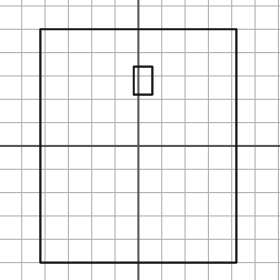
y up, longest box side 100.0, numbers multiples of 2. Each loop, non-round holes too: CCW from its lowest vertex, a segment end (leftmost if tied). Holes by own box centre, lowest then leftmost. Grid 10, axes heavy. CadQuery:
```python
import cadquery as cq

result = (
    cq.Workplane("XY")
    .moveTo(-42.0, -50.0)
    .lineTo(42.0, -50.0)
    .lineTo(42.0, 50.0)
    .lineTo(-42.0, 50.0)
    .close()
    .moveTo(-2.0, 22.0)
    .lineTo(6.0, 22.0)
    .lineTo(6.0, 34.0)
    .lineTo(-2.0, 34.0)
    .close()
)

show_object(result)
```